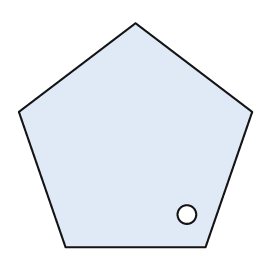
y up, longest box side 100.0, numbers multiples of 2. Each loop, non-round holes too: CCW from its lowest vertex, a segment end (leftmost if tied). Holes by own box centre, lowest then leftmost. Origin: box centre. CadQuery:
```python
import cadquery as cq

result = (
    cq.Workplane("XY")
    .moveTo(-30.0, -48.0)
    .lineTo(30.0, -48.0)
    .lineTo(50.0, 10.0)
    .lineTo(0.0, 48.0)
    .lineTo(-50.0, 10.0)
    .close()
    .moveTo(22.0, -34.0)
    .circle(4.0)
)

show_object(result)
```